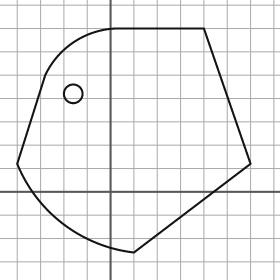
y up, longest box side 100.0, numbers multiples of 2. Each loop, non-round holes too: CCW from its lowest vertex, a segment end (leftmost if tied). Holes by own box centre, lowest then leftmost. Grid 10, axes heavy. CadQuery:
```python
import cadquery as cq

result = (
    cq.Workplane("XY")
    .moveTo(10.0, -26.0)
    .lineTo(60.0, 12.0)
    .lineTo(40.0, 70.0)
    .lineTo(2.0, 70.0)
    .threePointArc((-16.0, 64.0), (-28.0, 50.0))
    .lineTo(-40.0, 12.0)
    .threePointArc((-20.0, -14.0), (10.0, -26.0))
    .close()
    .moveTo(-16.0, 42.0)
    .circle(4.0)
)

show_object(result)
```